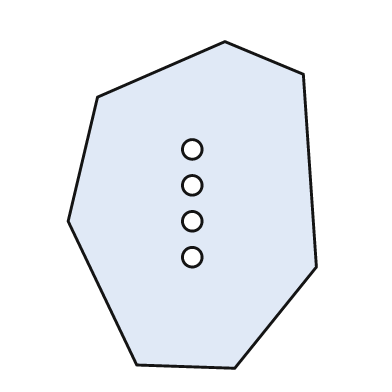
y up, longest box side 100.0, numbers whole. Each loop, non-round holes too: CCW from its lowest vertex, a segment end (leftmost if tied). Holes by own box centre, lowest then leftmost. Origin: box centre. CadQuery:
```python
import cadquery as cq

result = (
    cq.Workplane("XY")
    .moveTo(13.0, -50.0)
    .lineTo(38.0, -19.0)
    .lineTo(34.0, 40.0)
    .lineTo(10.0, 50.0)
    .lineTo(-29.0, 33.0)
    .lineTo(-38.0, -5.0)
    .lineTo(-17.0, -49.0)
    .close()
    .moveTo(0.0, -16.0)
    .circle(3.0)
    .moveTo(0.0, -5.0)
    .circle(3.0)
    .moveTo(0.0, 6.0)
    .circle(3.0)
    .moveTo(0.0, 17.0)
    .circle(3.0)
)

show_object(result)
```